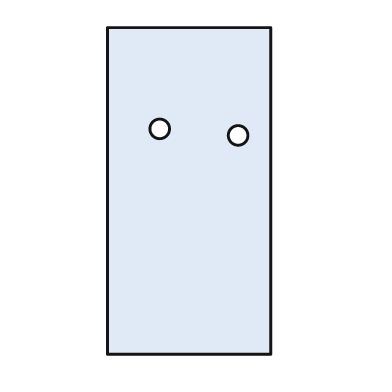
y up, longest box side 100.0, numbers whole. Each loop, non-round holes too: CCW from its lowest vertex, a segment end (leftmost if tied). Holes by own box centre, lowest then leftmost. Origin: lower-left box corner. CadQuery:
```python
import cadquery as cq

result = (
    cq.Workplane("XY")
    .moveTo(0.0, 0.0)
    .lineTo(50.0, 0.0)
    .lineTo(50.0, 100.0)
    .lineTo(0.0, 100.0)
    .close()
    .moveTo(40.0, 67.0)
    .circle(3.0)
    .moveTo(16.0, 69.0)
    .circle(3.0)
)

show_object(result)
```